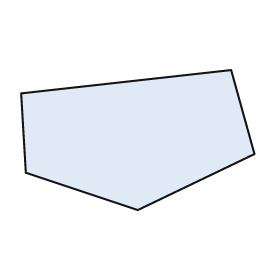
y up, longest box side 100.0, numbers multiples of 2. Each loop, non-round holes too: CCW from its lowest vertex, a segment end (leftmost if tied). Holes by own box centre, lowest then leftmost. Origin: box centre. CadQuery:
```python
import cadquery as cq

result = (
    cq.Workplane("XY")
    .moveTo(0.0, -30.0)
    .lineTo(50.0, -6.0)
    .lineTo(40.0, 30.0)
    .lineTo(-50.0, 20.0)
    .lineTo(-48.0, -14.0)
    .close()
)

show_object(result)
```